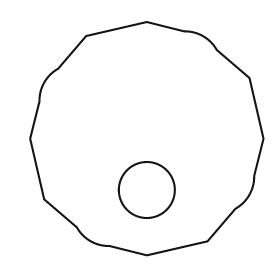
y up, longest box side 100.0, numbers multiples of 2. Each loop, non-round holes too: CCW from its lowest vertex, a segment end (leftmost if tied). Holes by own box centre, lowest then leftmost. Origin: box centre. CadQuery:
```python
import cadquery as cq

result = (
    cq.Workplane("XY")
    .moveTo(0.0, -50.0)
    .lineTo(26.0, -44.0)
    .lineTo(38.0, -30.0)
    .threePointArc((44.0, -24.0), (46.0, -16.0))
    .lineTo(50.0, 0.0)
    .lineTo(44.0, 26.0)
    .lineTo(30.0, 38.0)
    .threePointArc((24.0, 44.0), (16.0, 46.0))
    .lineTo(0.0, 50.0)
    .lineTo(-26.0, 44.0)
    .lineTo(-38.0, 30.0)
    .threePointArc((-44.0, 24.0), (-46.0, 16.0))
    .lineTo(-50.0, 0.0)
    .lineTo(-44.0, -26.0)
    .lineTo(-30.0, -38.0)
    .threePointArc((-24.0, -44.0), (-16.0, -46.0))
    .close()
    .moveTo(0.0, -22.0)
    .circle(12.0)
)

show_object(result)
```